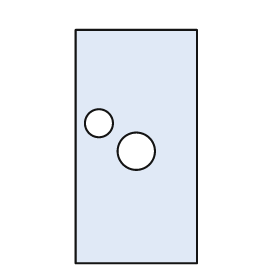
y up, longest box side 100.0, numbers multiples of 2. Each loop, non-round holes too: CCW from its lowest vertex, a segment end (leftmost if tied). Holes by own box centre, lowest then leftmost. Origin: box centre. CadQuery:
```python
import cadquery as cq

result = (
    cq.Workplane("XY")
    .moveTo(-26.0, -50.0)
    .lineTo(26.0, -50.0)
    .lineTo(26.0, 50.0)
    .lineTo(-26.0, 50.0)
    .close()
    .moveTo(0.0, -2.0)
    .circle(8.0)
    .moveTo(-16.0, 10.0)
    .circle(6.0)
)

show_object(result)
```